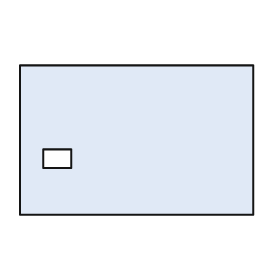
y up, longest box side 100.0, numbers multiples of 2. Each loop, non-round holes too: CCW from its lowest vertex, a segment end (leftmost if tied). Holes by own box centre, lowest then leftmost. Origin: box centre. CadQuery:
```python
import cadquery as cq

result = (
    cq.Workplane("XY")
    .moveTo(-50.0, -32.0)
    .lineTo(50.0, -32.0)
    .lineTo(50.0, 32.0)
    .lineTo(-50.0, 32.0)
    .close()
    .moveTo(-40.0, -12.0)
    .lineTo(-28.0, -12.0)
    .lineTo(-28.0, -4.0)
    .lineTo(-40.0, -4.0)
    .close()
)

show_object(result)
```